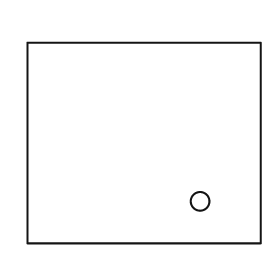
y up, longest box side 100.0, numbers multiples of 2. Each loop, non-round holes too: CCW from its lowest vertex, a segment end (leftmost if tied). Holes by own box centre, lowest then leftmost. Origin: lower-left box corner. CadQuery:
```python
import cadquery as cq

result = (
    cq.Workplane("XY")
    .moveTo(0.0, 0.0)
    .lineTo(100.0, 0.0)
    .lineTo(100.0, 86.0)
    .lineTo(0.0, 86.0)
    .close()
    .moveTo(74.0, 18.0)
    .circle(4.0)
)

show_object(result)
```